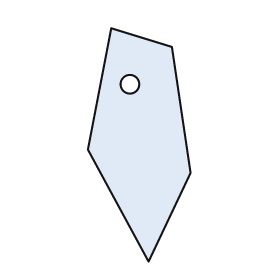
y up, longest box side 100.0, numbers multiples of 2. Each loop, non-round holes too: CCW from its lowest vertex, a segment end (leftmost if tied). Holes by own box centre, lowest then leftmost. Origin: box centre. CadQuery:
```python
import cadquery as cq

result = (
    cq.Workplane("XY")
    .moveTo(4.0, -50.0)
    .lineTo(22.0, -12.0)
    .lineTo(14.0, 42.0)
    .lineTo(-12.0, 50.0)
    .lineTo(-22.0, -2.0)
    .close()
    .moveTo(-4.0, 26.0)
    .circle(4.0)
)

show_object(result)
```